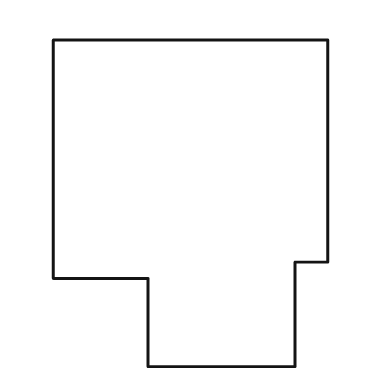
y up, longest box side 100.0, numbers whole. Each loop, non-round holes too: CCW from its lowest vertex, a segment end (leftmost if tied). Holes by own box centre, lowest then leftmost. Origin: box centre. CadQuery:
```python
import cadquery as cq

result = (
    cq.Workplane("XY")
    .moveTo(-13.0, -50.0)
    .lineTo(32.0, -50.0)
    .lineTo(32.0, -18.0)
    .lineTo(42.0, -18.0)
    .lineTo(42.0, 50.0)
    .lineTo(-42.0, 50.0)
    .lineTo(-42.0, -23.0)
    .lineTo(-13.0, -23.0)
    .close()
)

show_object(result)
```